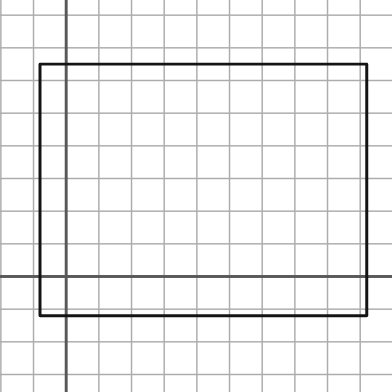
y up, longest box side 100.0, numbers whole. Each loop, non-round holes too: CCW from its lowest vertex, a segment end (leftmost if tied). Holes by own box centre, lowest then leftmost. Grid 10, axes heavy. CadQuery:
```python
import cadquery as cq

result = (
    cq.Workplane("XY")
    .moveTo(-8.0, -12.0)
    .lineTo(92.0, -12.0)
    .lineTo(92.0, 65.0)
    .lineTo(-8.0, 65.0)
    .close()
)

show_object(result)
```